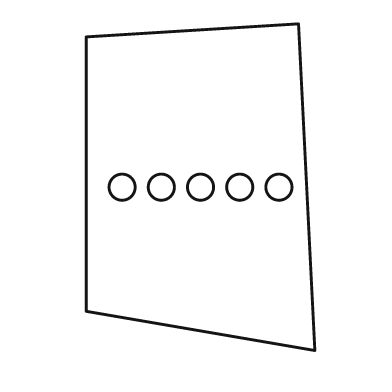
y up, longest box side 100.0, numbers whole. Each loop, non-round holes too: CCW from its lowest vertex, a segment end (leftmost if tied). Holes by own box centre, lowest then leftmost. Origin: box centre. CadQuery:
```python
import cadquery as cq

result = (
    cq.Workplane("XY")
    .moveTo(35.0, -50.0)
    .lineTo(30.0, 50.0)
    .lineTo(-35.0, 46.0)
    .lineTo(-35.0, -38.0)
    .close()
    .moveTo(-24.0, 0.0)
    .circle(4.0)
    .moveTo(-12.0, 0.0)
    .circle(4.0)
    .moveTo(0.0, 0.0)
    .circle(4.0)
    .moveTo(12.0, 0.0)
    .circle(4.0)
    .moveTo(24.0, 0.0)
    .circle(4.0)
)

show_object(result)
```